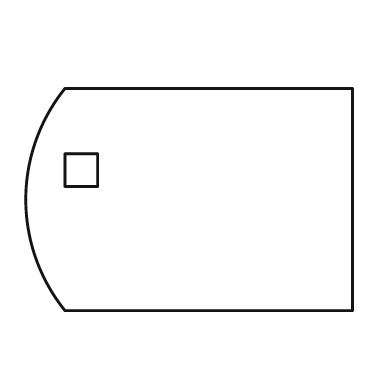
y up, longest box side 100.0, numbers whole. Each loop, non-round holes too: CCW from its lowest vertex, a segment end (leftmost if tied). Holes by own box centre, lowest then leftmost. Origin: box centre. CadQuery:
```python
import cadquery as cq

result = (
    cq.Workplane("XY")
    .moveTo(-38.0, -34.0)
    .lineTo(50.0, -34.0)
    .lineTo(50.0, 34.0)
    .lineTo(-38.0, 34.0)
    .threePointArc((-50.0, 0.0), (-38.0, -34.0))
    .close()
    .moveTo(-38.0, 4.0)
    .lineTo(-28.0, 4.0)
    .lineTo(-28.0, 14.0)
    .lineTo(-38.0, 14.0)
    .close()
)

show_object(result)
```